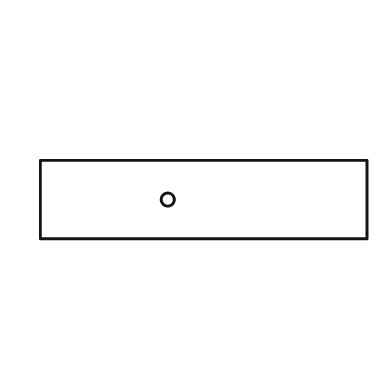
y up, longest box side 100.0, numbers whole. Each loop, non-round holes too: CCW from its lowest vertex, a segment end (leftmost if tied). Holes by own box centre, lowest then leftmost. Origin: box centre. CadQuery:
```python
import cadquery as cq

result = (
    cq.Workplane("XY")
    .moveTo(-50.0, -12.0)
    .lineTo(50.0, -12.0)
    .lineTo(50.0, 12.0)
    .lineTo(-50.0, 12.0)
    .close()
    .moveTo(-11.0, 0.0)
    .circle(2.0)
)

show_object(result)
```